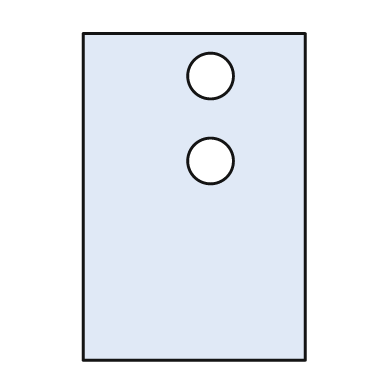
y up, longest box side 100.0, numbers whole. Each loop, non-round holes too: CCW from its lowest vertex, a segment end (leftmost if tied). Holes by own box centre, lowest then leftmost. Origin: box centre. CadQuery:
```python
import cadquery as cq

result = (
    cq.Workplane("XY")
    .moveTo(-34.0, -50.0)
    .lineTo(34.0, -50.0)
    .lineTo(34.0, 50.0)
    .lineTo(-34.0, 50.0)
    .close()
    .moveTo(5.0, 11.0)
    .circle(7.0)
    .moveTo(5.0, 37.0)
    .circle(7.0)
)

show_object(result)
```